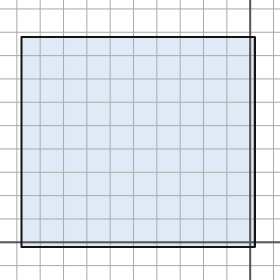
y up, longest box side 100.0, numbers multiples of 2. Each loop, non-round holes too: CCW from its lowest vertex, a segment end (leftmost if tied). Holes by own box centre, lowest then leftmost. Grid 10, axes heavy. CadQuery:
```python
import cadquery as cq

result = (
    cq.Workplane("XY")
    .moveTo(-98.0, -2.0)
    .lineTo(2.0, -2.0)
    .lineTo(2.0, 88.0)
    .lineTo(-98.0, 88.0)
    .close()
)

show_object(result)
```